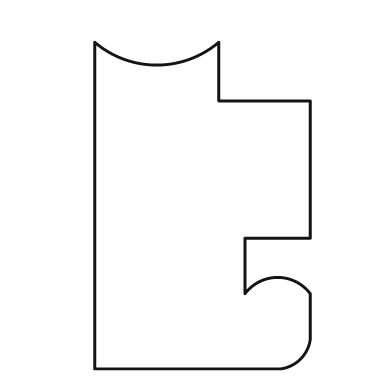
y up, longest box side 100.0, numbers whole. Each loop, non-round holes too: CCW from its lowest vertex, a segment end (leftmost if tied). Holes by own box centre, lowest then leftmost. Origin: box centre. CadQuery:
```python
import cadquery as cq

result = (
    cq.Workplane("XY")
    .moveTo(-33.0, -50.0)
    .lineTo(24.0, -50.0)
    .threePointArc((30.0, -47.0), (33.0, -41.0))
    .lineTo(33.0, -27.0)
    .threePointArc((23.0, -22.0), (13.0, -27.0))
    .lineTo(13.0, -10.0)
    .lineTo(33.0, -10.0)
    .lineTo(33.0, 32.0)
    .lineTo(5.0, 32.0)
    .lineTo(5.0, 50.0)
    .threePointArc((-14.0, 43.0), (-33.0, 50.0))
    .close()
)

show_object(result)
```